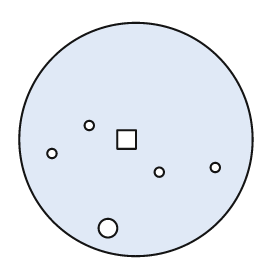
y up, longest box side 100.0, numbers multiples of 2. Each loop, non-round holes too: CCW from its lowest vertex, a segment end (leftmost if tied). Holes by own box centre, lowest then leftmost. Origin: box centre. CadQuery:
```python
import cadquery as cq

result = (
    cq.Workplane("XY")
    .moveTo(0.0, 0.0)
    .circle(50.0)
    .moveTo(-12.0, -38.0)
    .circle(4.0)
    .moveTo(10.0, -14.0)
    .circle(2.0)
    .moveTo(34.0, -12.0)
    .circle(2.0)
    .moveTo(-36.0, -6.0)
    .circle(2.0)
    .moveTo(-8.0, -4.0)
    .lineTo(0.0, -4.0)
    .lineTo(0.0, 4.0)
    .lineTo(-8.0, 4.0)
    .close()
    .moveTo(-20.0, 6.0)
    .circle(2.0)
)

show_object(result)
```